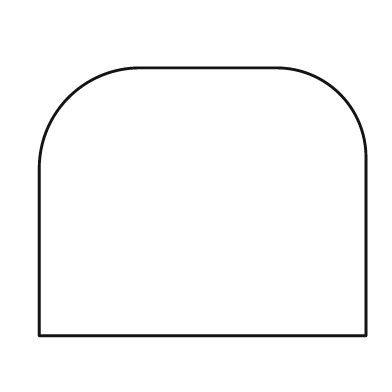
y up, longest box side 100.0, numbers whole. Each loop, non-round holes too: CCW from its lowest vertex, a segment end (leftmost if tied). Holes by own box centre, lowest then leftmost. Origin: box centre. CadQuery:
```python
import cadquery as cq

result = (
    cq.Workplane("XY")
    .moveTo(-50.0, -41.0)
    .lineTo(50.0, -41.0)
    .lineTo(50.0, 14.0)
    .threePointArc((42.0, 33.0), (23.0, 41.0))
    .lineTo(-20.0, 41.0)
    .threePointArc((-41.0, 32.0), (-50.0, 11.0))
    .close()
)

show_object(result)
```